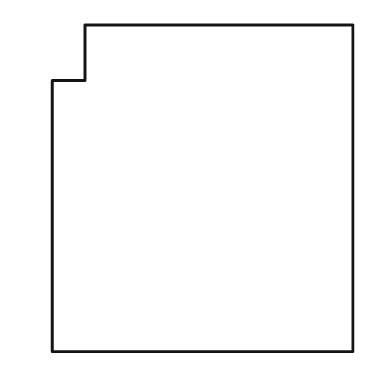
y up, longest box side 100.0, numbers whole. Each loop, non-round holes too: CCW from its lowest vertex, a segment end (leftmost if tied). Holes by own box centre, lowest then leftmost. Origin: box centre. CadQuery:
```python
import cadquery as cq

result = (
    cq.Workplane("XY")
    .moveTo(-46.0, -50.0)
    .lineTo(46.0, -50.0)
    .lineTo(46.0, 50.0)
    .lineTo(-36.0, 50.0)
    .lineTo(-36.0, 33.0)
    .lineTo(-46.0, 33.0)
    .close()
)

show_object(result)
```